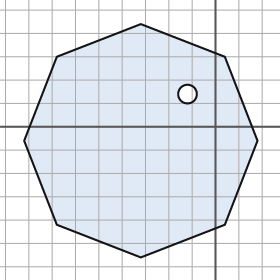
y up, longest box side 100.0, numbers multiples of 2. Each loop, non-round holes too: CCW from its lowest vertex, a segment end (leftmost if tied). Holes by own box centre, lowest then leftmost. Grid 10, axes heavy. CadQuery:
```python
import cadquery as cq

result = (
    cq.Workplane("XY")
    .moveTo(-32.0, -56.0)
    .lineTo(4.0, -42.0)
    .lineTo(18.0, -6.0)
    .lineTo(4.0, 30.0)
    .lineTo(-32.0, 44.0)
    .lineTo(-68.0, 30.0)
    .lineTo(-82.0, -6.0)
    .lineTo(-68.0, -42.0)
    .close()
    .moveTo(-12.0, 14.0)
    .circle(4.0)
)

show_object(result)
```